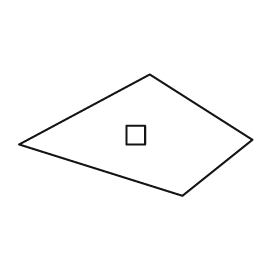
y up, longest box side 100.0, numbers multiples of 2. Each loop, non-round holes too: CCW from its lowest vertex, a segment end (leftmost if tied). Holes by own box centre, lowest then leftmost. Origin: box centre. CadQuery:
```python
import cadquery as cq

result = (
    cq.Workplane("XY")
    .moveTo(20.0, -26.0)
    .lineTo(50.0, -2.0)
    .lineTo(6.0, 26.0)
    .lineTo(-50.0, -4.0)
    .close()
    .moveTo(-4.0, -4.0)
    .lineTo(4.0, -4.0)
    .lineTo(4.0, 4.0)
    .lineTo(-4.0, 4.0)
    .close()
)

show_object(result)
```